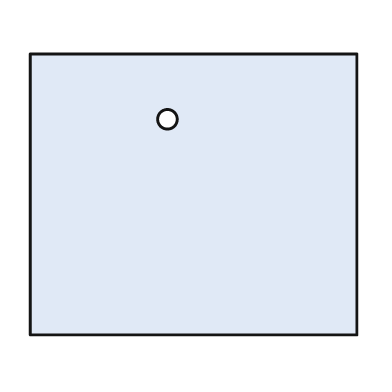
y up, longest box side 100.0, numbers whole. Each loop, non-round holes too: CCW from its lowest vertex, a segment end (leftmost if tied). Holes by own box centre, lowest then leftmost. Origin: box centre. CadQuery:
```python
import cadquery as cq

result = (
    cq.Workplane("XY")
    .moveTo(-50.0, -43.0)
    .lineTo(50.0, -43.0)
    .lineTo(50.0, 43.0)
    .lineTo(-50.0, 43.0)
    .close()
    .moveTo(-8.0, 23.0)
    .circle(3.0)
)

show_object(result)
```